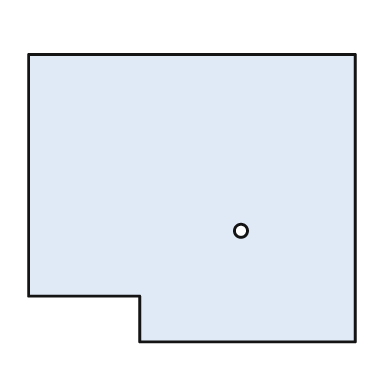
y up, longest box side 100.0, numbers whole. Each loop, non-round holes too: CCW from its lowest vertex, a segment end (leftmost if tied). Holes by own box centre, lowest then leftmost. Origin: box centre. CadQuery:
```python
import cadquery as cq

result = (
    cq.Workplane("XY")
    .moveTo(-16.0, -44.0)
    .lineTo(50.0, -44.0)
    .lineTo(50.0, 44.0)
    .lineTo(-50.0, 44.0)
    .lineTo(-50.0, -30.0)
    .lineTo(-16.0, -30.0)
    .close()
    .moveTo(15.0, -10.0)
    .circle(2.0)
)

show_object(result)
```